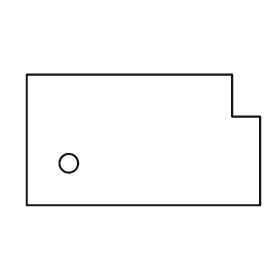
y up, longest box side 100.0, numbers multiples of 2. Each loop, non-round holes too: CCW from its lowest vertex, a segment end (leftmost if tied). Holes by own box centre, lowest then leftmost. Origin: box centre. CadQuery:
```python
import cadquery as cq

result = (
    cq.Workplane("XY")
    .moveTo(-50.0, -28.0)
    .lineTo(50.0, -28.0)
    .lineTo(50.0, 10.0)
    .lineTo(38.0, 10.0)
    .lineTo(38.0, 28.0)
    .lineTo(-50.0, 28.0)
    .close()
    .moveTo(-32.0, -10.0)
    .circle(4.0)
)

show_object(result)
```